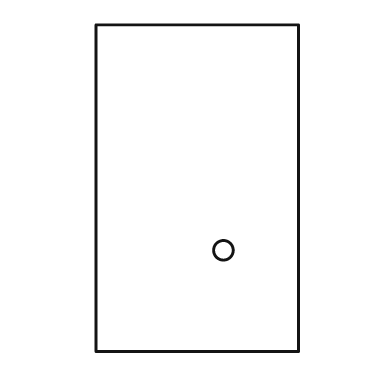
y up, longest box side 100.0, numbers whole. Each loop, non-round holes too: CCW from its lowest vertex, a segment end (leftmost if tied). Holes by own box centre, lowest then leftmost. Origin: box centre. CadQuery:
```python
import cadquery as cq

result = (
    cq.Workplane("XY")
    .moveTo(-31.0, -50.0)
    .lineTo(31.0, -50.0)
    .lineTo(31.0, 50.0)
    .lineTo(-31.0, 50.0)
    .close()
    .moveTo(8.0, -19.0)
    .circle(3.0)
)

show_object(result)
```